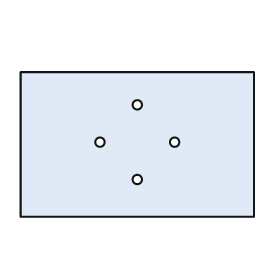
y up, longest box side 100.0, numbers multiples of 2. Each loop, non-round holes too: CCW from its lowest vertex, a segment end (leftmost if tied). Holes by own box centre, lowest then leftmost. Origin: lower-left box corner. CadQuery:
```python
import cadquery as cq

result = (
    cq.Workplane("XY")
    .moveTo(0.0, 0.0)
    .lineTo(100.0, 0.0)
    .lineTo(100.0, 62.0)
    .lineTo(0.0, 62.0)
    .close()
    .moveTo(50.0, 16.0)
    .circle(2.0)
    .moveTo(34.0, 32.0)
    .circle(2.0)
    .moveTo(66.0, 32.0)
    .circle(2.0)
    .moveTo(50.0, 48.0)
    .circle(2.0)
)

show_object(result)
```